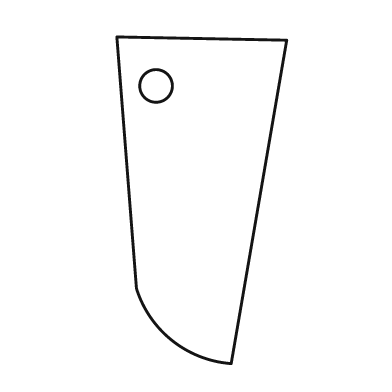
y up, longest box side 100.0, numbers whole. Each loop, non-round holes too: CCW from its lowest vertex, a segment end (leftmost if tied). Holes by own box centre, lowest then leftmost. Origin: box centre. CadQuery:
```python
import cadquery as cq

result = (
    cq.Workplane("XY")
    .moveTo(9.0, -50.0)
    .lineTo(26.0, 49.0)
    .lineTo(-26.0, 50.0)
    .lineTo(-20.0, -27.0)
    .threePointArc((-9.0, -43.0), (9.0, -50.0))
    .close()
    .moveTo(-14.0, 35.0)
    .circle(5.0)
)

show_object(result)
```